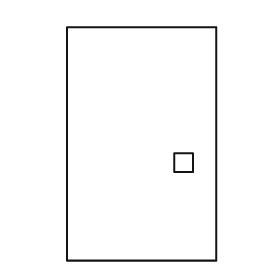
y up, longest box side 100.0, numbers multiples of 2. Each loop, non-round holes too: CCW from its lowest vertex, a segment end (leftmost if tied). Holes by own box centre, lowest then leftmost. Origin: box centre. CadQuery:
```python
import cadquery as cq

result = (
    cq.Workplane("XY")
    .moveTo(-32.0, -50.0)
    .lineTo(32.0, -50.0)
    .lineTo(32.0, 50.0)
    .lineTo(-32.0, 50.0)
    .close()
    .moveTo(14.0, -12.0)
    .lineTo(22.0, -12.0)
    .lineTo(22.0, -4.0)
    .lineTo(14.0, -4.0)
    .close()
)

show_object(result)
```